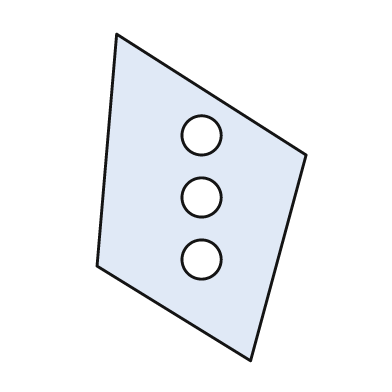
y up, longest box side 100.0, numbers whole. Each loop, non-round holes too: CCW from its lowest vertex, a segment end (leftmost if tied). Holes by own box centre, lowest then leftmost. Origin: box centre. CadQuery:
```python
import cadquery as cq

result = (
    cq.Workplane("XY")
    .moveTo(15.0, -50.0)
    .lineTo(32.0, 13.0)
    .lineTo(-26.0, 50.0)
    .lineTo(-32.0, -21.0)
    .close()
    .moveTo(0.0, -19.0)
    .circle(6.0)
    .moveTo(0.0, 0.0)
    .circle(6.0)
    .moveTo(0.0, 19.0)
    .circle(6.0)
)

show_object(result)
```